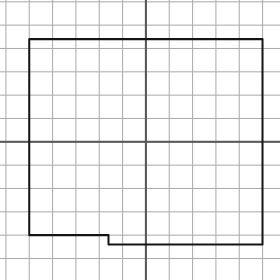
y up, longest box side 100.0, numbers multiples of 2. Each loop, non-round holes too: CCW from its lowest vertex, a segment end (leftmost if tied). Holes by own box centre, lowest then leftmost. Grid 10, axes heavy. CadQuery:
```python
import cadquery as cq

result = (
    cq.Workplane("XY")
    .moveTo(-16.0, -44.0)
    .lineTo(50.0, -44.0)
    .lineTo(50.0, 44.0)
    .lineTo(-50.0, 44.0)
    .lineTo(-50.0, -40.0)
    .lineTo(-16.0, -40.0)
    .close()
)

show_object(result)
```